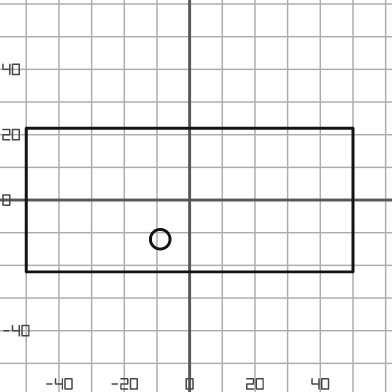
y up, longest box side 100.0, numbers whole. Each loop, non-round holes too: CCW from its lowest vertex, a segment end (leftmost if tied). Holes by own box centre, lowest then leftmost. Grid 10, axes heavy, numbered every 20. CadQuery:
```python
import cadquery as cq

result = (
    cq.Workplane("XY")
    .moveTo(-50.0, -22.0)
    .lineTo(50.0, -22.0)
    .lineTo(50.0, 22.0)
    .lineTo(-50.0, 22.0)
    .close()
    .moveTo(-9.0, -12.0)
    .circle(3.0)
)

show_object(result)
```